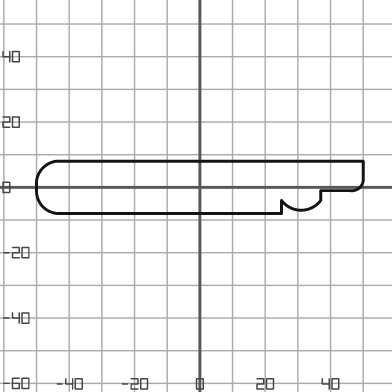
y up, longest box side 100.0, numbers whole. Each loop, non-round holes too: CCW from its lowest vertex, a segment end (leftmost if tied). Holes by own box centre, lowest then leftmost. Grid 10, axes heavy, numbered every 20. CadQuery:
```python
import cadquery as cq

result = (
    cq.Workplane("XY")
    .moveTo(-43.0, -8.0)
    .lineTo(25.0, -8.0)
    .lineTo(25.0, -4.0)
    .threePointArc((31.0, -7.0), (37.0, -4.0))
    .lineTo(37.0, -1.0)
    .lineTo(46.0, -1.0)
    .threePointArc((49.0, 0.0), (50.0, 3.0))
    .lineTo(50.0, 8.0)
    .lineTo(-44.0, 8.0)
    .threePointArc((-48.0, 6.0), (-50.0, 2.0))
    .lineTo(-50.0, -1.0)
    .threePointArc((-48.0, -6.0), (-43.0, -8.0))
    .close()
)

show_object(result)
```